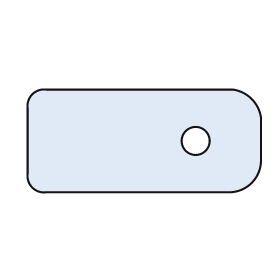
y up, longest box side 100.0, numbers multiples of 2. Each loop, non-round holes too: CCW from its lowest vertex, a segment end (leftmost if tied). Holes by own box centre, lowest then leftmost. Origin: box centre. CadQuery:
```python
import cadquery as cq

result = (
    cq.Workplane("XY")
    .moveTo(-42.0, -22.0)
    .lineTo(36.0, -22.0)
    .threePointArc((46.0, -18.0), (50.0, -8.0))
    .lineTo(50.0, 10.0)
    .threePointArc((46.0, 18.0), (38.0, 22.0))
    .lineTo(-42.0, 22.0)
    .threePointArc((-48.0, 20.0), (-50.0, 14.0))
    .lineTo(-50.0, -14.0)
    .threePointArc((-48.0, -20.0), (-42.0, -22.0))
    .close()
    .moveTo(22.0, 0.0)
    .circle(6.0)
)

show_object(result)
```